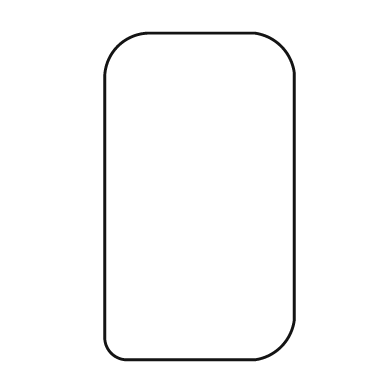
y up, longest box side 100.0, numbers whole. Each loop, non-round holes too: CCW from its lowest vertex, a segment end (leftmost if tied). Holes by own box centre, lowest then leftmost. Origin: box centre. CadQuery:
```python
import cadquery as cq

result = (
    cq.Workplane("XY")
    .moveTo(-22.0, -50.0)
    .lineTo(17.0, -50.0)
    .threePointArc((25.0, -46.0), (29.0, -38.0))
    .lineTo(29.0, 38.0)
    .threePointArc((25.0, 46.0), (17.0, 50.0))
    .lineTo(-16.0, 50.0)
    .threePointArc((-25.0, 46.0), (-29.0, 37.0))
    .lineTo(-29.0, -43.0)
    .threePointArc((-27.0, -48.0), (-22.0, -50.0))
    .close()
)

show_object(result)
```